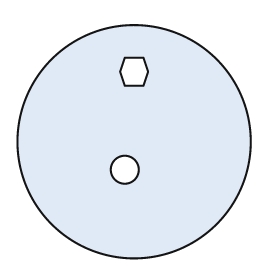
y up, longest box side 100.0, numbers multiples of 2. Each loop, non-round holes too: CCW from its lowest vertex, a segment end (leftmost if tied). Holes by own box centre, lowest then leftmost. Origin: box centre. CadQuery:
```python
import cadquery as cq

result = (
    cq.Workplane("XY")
    .moveTo(0.0, 0.0)
    .circle(50.0)
    .moveTo(-4.0, -12.0)
    .circle(6.0)
    .moveTo(-4.0, 24.0)
    .lineTo(4.0, 24.0)
    .lineTo(6.0, 30.0)
    .lineTo(4.0, 36.0)
    .lineTo(-4.0, 36.0)
    .lineTo(-6.0, 30.0)
    .close()
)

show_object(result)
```